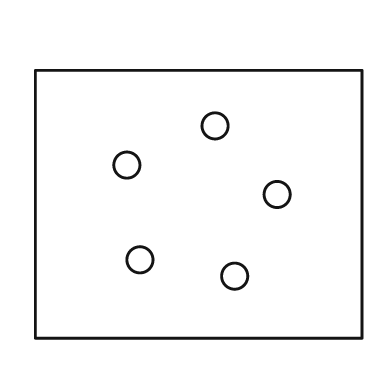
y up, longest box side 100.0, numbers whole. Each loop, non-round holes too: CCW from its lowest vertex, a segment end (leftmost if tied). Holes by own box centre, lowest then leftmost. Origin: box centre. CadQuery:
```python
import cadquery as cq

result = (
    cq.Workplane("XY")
    .moveTo(-50.0, -41.0)
    .lineTo(50.0, -41.0)
    .lineTo(50.0, 41.0)
    .lineTo(-50.0, 41.0)
    .close()
    .moveTo(11.0, -22.0)
    .circle(4.0)
    .moveTo(-18.0, -17.0)
    .circle(4.0)
    .moveTo(24.0, 3.0)
    .circle(4.0)
    .moveTo(-22.0, 12.0)
    .circle(4.0)
    .moveTo(5.0, 24.0)
    .circle(4.0)
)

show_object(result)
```